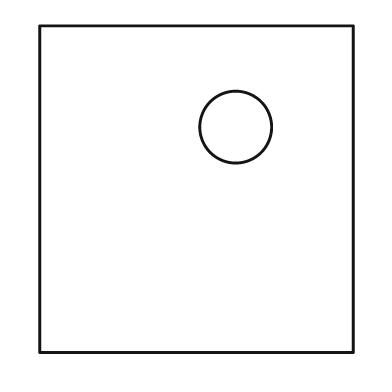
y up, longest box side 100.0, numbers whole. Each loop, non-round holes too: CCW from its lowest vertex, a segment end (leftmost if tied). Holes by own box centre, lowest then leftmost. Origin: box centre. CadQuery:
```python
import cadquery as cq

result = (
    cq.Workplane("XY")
    .moveTo(-48.0, -50.0)
    .lineTo(48.0, -50.0)
    .lineTo(48.0, 50.0)
    .lineTo(-48.0, 50.0)
    .close()
    .moveTo(12.0, 19.0)
    .circle(11.0)
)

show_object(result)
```